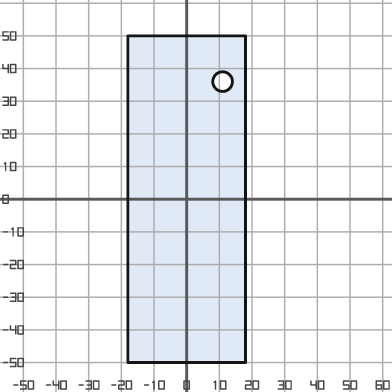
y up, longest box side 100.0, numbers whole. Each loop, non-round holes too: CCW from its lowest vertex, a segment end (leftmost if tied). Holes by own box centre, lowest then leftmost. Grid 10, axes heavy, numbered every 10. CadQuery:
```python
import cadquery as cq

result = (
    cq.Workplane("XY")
    .moveTo(-18.0, -50.0)
    .lineTo(18.0, -50.0)
    .lineTo(18.0, 50.0)
    .lineTo(-18.0, 50.0)
    .close()
    .moveTo(11.0, 36.0)
    .circle(3.0)
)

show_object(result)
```